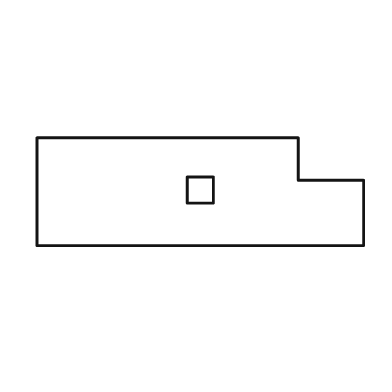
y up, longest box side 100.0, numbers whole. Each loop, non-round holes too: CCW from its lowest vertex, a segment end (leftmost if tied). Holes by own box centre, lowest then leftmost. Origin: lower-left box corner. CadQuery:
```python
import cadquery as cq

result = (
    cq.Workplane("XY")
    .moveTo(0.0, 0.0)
    .lineTo(100.0, 0.0)
    .lineTo(100.0, 20.0)
    .lineTo(80.0, 20.0)
    .lineTo(80.0, 33.0)
    .lineTo(0.0, 33.0)
    .close()
    .moveTo(46.0, 13.0)
    .lineTo(54.0, 13.0)
    .lineTo(54.0, 21.0)
    .lineTo(46.0, 21.0)
    .close()
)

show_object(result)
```